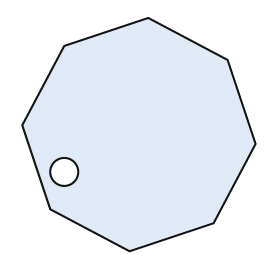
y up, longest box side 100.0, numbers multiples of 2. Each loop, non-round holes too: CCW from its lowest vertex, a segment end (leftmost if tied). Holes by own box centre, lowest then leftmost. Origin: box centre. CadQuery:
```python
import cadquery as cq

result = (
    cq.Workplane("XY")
    .moveTo(-4.0, -50.0)
    .lineTo(32.0, -38.0)
    .lineTo(50.0, -4.0)
    .lineTo(38.0, 32.0)
    .lineTo(4.0, 50.0)
    .lineTo(-32.0, 38.0)
    .lineTo(-50.0, 4.0)
    .lineTo(-38.0, -32.0)
    .close()
    .moveTo(-32.0, -16.0)
    .circle(6.0)
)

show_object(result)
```